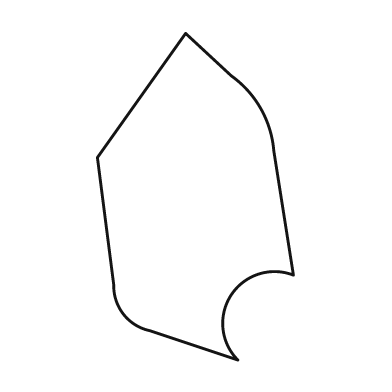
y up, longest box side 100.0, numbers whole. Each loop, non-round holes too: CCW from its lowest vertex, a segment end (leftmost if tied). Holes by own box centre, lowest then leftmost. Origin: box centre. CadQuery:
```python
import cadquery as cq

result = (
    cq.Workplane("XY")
    .moveTo(13.0, -50.0)
    .threePointArc((11.0, -30.0), (30.0, -24.0))
    .lineTo(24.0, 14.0)
    .threePointArc((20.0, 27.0), (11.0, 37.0))
    .lineTo(-3.0, 50.0)
    .lineTo(-30.0, 12.0)
    .lineTo(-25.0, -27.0)
    .threePointArc((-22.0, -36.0), (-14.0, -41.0))
    .close()
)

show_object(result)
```